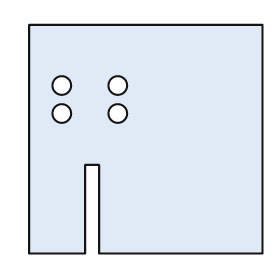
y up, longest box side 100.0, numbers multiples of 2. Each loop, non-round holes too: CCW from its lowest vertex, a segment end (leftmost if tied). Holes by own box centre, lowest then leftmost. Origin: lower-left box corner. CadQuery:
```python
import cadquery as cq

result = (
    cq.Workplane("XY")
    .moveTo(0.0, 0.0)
    .lineTo(24.0, 0.0)
    .lineTo(24.0, 38.0)
    .lineTo(30.0, 38.0)
    .lineTo(30.0, 0.0)
    .lineTo(100.0, 0.0)
    .lineTo(100.0, 98.0)
    .lineTo(0.0, 98.0)
    .close()
    .moveTo(14.0, 60.0)
    .circle(4.0)
    .moveTo(38.0, 60.0)
    .circle(4.0)
    .moveTo(14.0, 72.0)
    .circle(4.0)
    .moveTo(38.0, 72.0)
    .circle(4.0)
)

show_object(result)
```